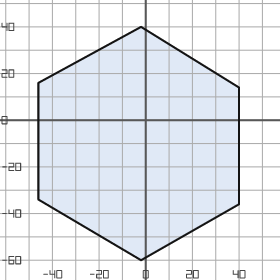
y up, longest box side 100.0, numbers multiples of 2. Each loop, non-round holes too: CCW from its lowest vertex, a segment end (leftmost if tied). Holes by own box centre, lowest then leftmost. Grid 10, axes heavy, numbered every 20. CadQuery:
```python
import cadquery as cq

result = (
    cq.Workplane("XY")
    .moveTo(-2.0, -60.0)
    .lineTo(40.0, -36.0)
    .lineTo(40.0, 14.0)
    .lineTo(-2.0, 40.0)
    .lineTo(-46.0, 16.0)
    .lineTo(-46.0, -34.0)
    .close()
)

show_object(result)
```